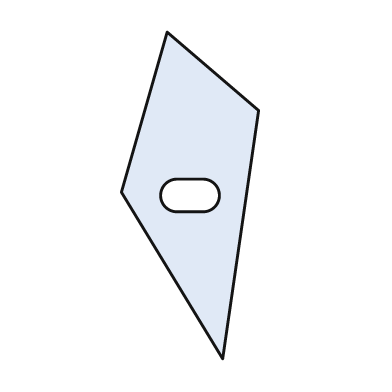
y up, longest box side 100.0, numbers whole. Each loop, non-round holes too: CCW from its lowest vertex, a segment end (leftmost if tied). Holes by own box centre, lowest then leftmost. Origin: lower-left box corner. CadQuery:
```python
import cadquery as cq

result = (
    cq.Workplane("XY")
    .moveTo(31.0, 0.0)
    .lineTo(42.0, 76.0)
    .lineTo(14.0, 100.0)
    .lineTo(0.0, 51.0)
    .close()
    .moveTo(17.0, 45.0)
    .lineTo(25.0, 45.0)
    .threePointArc((30.0, 50.0), (25.0, 55.0))
    .lineTo(17.0, 55.0)
    .threePointArc((12.0, 50.0), (17.0, 45.0))
    .close()
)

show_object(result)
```